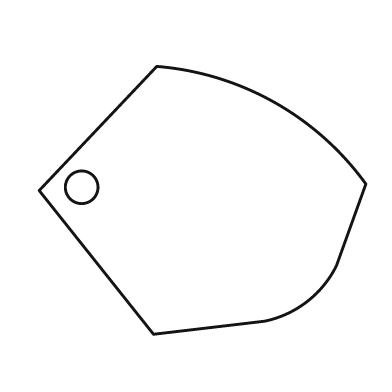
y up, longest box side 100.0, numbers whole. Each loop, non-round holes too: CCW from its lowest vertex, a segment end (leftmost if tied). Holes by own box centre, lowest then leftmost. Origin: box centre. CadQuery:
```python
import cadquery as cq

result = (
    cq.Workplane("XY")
    .moveTo(-15.0, -41.0)
    .lineTo(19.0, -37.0)
    .threePointArc((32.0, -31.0), (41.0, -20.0))
    .lineTo(50.0, 5.0)
    .threePointArc((22.0, 30.0), (-14.0, 41.0))
    .lineTo(-50.0, 3.0)
    .close()
    .moveTo(-37.0, 4.0)
    .circle(5.0)
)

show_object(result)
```